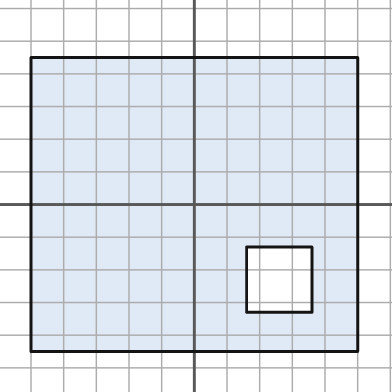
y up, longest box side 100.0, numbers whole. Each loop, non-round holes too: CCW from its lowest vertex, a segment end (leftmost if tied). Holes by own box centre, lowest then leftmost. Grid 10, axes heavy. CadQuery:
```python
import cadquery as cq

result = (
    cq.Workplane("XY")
    .moveTo(-50.0, -45.0)
    .lineTo(50.0, -45.0)
    .lineTo(50.0, 45.0)
    .lineTo(-50.0, 45.0)
    .close()
    .moveTo(16.0, -33.0)
    .lineTo(36.0, -33.0)
    .lineTo(36.0, -13.0)
    .lineTo(16.0, -13.0)
    .close()
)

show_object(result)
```